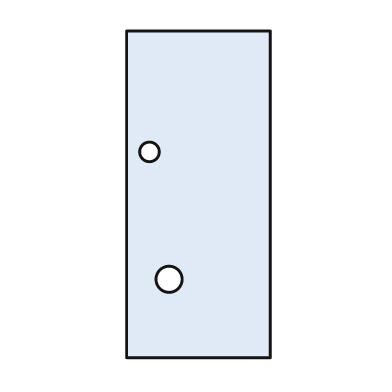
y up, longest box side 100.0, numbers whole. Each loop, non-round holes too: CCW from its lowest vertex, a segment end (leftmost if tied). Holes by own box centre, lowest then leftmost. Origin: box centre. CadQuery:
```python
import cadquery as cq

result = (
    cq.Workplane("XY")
    .moveTo(-22.0, -50.0)
    .lineTo(22.0, -50.0)
    .lineTo(22.0, 50.0)
    .lineTo(-22.0, 50.0)
    .close()
    .moveTo(-9.0, -26.0)
    .circle(4.0)
    .moveTo(-15.0, 13.0)
    .circle(3.0)
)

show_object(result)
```